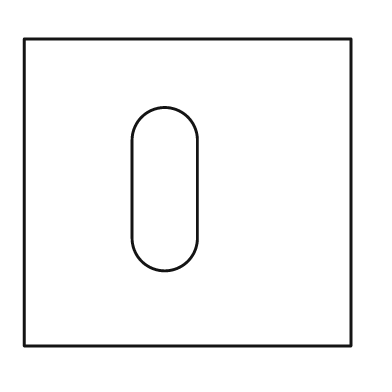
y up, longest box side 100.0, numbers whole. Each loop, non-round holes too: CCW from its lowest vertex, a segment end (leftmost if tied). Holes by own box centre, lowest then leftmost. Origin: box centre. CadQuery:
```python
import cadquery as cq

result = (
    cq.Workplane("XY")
    .moveTo(-50.0, -47.0)
    .lineTo(50.0, -47.0)
    .lineTo(50.0, 47.0)
    .lineTo(-50.0, 47.0)
    .close()
    .moveTo(-17.0, -14.0)
    .threePointArc((-7.0, -24.0), (3.0, -14.0))
    .lineTo(3.0, 16.0)
    .threePointArc((-7.0, 26.0), (-17.0, 16.0))
    .close()
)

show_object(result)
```